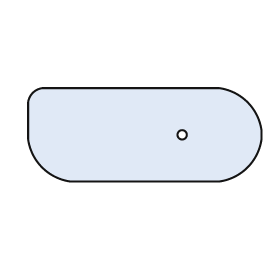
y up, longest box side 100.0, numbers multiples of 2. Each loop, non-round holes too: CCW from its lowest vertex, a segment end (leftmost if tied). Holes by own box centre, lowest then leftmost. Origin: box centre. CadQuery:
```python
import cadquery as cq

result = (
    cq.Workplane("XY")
    .moveTo(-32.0, -20.0)
    .lineTo(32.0, -20.0)
    .threePointArc((44.0, -14.0), (50.0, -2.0))
    .lineTo(50.0, 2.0)
    .threePointArc((44.0, 14.0), (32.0, 20.0))
    .lineTo(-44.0, 20.0)
    .threePointArc((-48.0, 18.0), (-50.0, 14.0))
    .lineTo(-50.0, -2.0)
    .threePointArc((-44.0, -14.0), (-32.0, -20.0))
    .close()
    .moveTo(16.0, 0.0)
    .circle(2.0)
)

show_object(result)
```